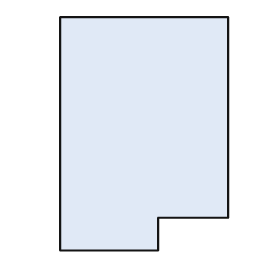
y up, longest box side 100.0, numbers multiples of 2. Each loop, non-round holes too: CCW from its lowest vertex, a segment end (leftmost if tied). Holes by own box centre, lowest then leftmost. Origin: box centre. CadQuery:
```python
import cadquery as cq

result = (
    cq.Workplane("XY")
    .moveTo(-36.0, -50.0)
    .lineTo(6.0, -50.0)
    .lineTo(6.0, -36.0)
    .lineTo(36.0, -36.0)
    .lineTo(36.0, 50.0)
    .lineTo(-36.0, 50.0)
    .close()
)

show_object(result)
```